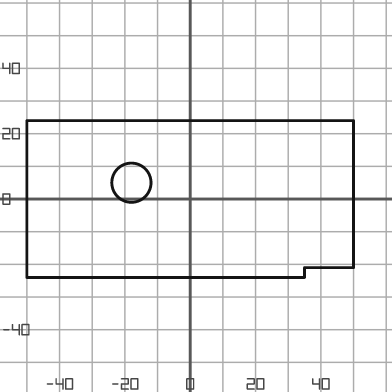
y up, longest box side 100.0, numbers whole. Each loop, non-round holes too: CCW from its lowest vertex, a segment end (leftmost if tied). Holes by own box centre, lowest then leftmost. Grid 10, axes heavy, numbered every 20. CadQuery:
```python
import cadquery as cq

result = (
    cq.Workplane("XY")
    .moveTo(-50.0, -24.0)
    .lineTo(35.0, -24.0)
    .lineTo(35.0, -21.0)
    .lineTo(50.0, -21.0)
    .lineTo(50.0, 24.0)
    .lineTo(-50.0, 24.0)
    .close()
    .moveTo(-18.0, 5.0)
    .circle(6.0)
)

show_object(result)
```